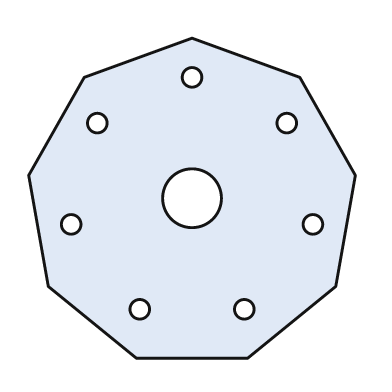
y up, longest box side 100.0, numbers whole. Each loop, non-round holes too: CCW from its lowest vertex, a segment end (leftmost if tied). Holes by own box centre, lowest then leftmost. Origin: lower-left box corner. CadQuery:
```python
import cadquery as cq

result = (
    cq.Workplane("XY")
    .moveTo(33.0, 0.0)
    .lineTo(67.0, 0.0)
    .lineTo(94.0, 22.0)
    .lineTo(100.0, 56.0)
    .lineTo(83.0, 86.0)
    .lineTo(50.0, 98.0)
    .lineTo(17.0, 86.0)
    .lineTo(0.0, 56.0)
    .lineTo(6.0, 22.0)
    .close()
    .moveTo(34.0, 15.0)
    .circle(3.0)
    .moveTo(66.0, 15.0)
    .circle(3.0)
    .moveTo(13.0, 41.0)
    .circle(3.0)
    .moveTo(87.0, 41.0)
    .circle(3.0)
    .moveTo(50.0, 49.0)
    .circle(9.0)
    .moveTo(21.0, 72.0)
    .circle(3.0)
    .moveTo(79.0, 72.0)
    .circle(3.0)
    .moveTo(50.0, 86.0)
    .circle(3.0)
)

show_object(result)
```